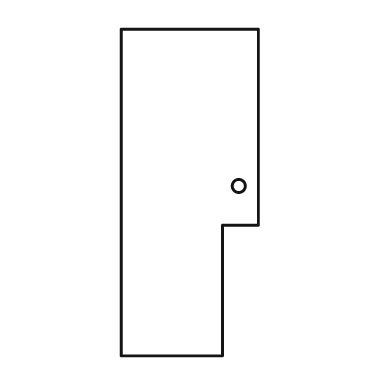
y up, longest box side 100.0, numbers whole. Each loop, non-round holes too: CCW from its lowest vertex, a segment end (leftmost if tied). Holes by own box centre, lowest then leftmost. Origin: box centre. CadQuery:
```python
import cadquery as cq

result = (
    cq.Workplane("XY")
    .moveTo(-21.0, -50.0)
    .lineTo(10.0, -50.0)
    .lineTo(10.0, -10.0)
    .lineTo(21.0, -10.0)
    .lineTo(21.0, 50.0)
    .lineTo(-21.0, 50.0)
    .close()
    .moveTo(15.0, 2.0)
    .circle(2.0)
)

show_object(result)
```